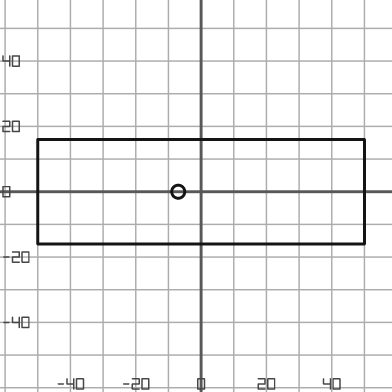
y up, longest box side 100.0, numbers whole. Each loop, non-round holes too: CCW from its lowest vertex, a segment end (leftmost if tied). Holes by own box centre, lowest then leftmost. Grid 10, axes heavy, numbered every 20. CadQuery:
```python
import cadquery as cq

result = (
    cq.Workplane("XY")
    .moveTo(-50.0, -16.0)
    .lineTo(50.0, -16.0)
    .lineTo(50.0, 16.0)
    .lineTo(-50.0, 16.0)
    .close()
    .moveTo(-7.0, 0.0)
    .circle(2.0)
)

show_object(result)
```